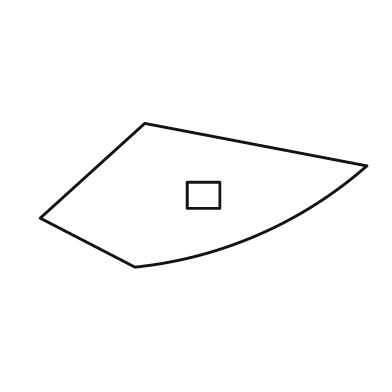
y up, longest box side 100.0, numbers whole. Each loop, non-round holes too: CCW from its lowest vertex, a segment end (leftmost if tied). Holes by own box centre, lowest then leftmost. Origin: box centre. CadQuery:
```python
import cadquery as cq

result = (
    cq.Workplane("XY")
    .moveTo(-21.0, -22.0)
    .threePointArc((17.0, -12.0), (50.0, 9.0))
    .lineTo(-18.0, 22.0)
    .lineTo(-50.0, -7.0)
    .close()
    .moveTo(-5.0, -4.0)
    .lineTo(5.0, -4.0)
    .lineTo(5.0, 4.0)
    .lineTo(-5.0, 4.0)
    .close()
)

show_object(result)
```